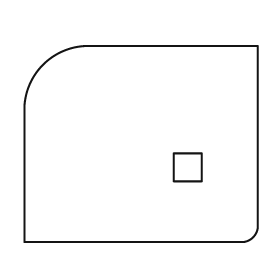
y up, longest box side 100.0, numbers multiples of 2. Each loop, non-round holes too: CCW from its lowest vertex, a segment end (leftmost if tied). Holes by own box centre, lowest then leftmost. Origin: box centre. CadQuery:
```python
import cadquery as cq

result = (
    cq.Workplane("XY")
    .moveTo(-50.0, -42.0)
    .lineTo(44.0, -42.0)
    .threePointArc((48.0, -40.0), (50.0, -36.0))
    .lineTo(50.0, 42.0)
    .lineTo(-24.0, 42.0)
    .threePointArc((-42.0, 34.0), (-50.0, 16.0))
    .close()
    .moveTo(14.0, -16.0)
    .lineTo(26.0, -16.0)
    .lineTo(26.0, -4.0)
    .lineTo(14.0, -4.0)
    .close()
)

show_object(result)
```